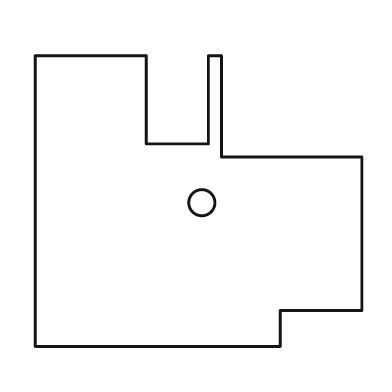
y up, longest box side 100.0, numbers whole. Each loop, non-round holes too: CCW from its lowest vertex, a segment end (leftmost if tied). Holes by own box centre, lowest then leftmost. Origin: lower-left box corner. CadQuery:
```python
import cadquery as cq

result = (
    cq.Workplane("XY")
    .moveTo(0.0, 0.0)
    .lineTo(75.0, 0.0)
    .lineTo(75.0, 11.0)
    .lineTo(100.0, 11.0)
    .lineTo(100.0, 58.0)
    .lineTo(57.0, 58.0)
    .lineTo(57.0, 89.0)
    .lineTo(53.0, 89.0)
    .lineTo(53.0, 62.0)
    .lineTo(34.0, 62.0)
    .lineTo(34.0, 89.0)
    .lineTo(0.0, 89.0)
    .close()
    .moveTo(51.0, 44.0)
    .circle(4.0)
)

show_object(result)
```